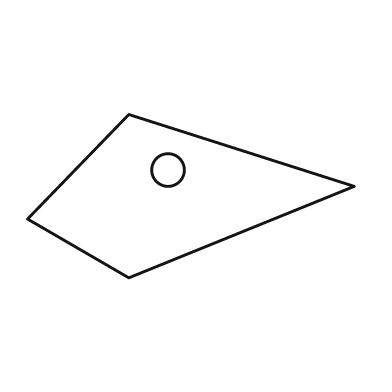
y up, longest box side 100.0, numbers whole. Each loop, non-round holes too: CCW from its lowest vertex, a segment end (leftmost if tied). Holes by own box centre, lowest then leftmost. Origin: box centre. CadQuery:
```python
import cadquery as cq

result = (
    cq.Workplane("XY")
    .moveTo(-19.0, -25.0)
    .lineTo(50.0, 3.0)
    .lineTo(-19.0, 25.0)
    .lineTo(-50.0, -7.0)
    .close()
    .moveTo(-7.0, 8.0)
    .circle(5.0)
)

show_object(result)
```